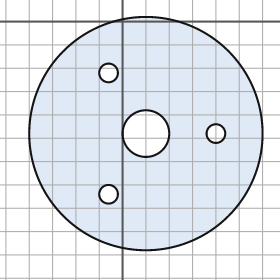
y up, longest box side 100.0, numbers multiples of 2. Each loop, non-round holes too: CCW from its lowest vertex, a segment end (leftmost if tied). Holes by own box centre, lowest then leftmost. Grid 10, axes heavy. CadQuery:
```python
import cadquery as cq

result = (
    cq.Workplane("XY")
    .moveTo(10.0, -48.0)
    .circle(50.0)
    .moveTo(-6.0, -74.0)
    .circle(4.0)
    .moveTo(10.0, -48.0)
    .circle(10.0)
    .moveTo(40.0, -48.0)
    .circle(4.0)
    .moveTo(-6.0, -22.0)
    .circle(4.0)
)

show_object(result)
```